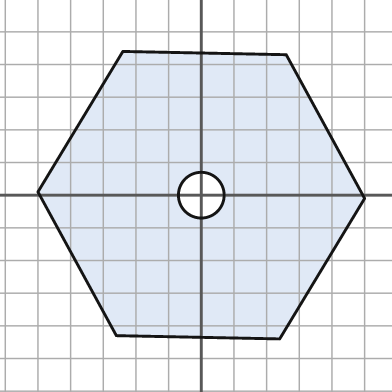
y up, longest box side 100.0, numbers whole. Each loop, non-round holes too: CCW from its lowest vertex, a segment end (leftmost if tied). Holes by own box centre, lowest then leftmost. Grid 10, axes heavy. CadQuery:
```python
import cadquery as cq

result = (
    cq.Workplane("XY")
    .moveTo(24.0, -44.0)
    .lineTo(50.0, -1.0)
    .lineTo(26.0, 43.0)
    .lineTo(-24.0, 44.0)
    .lineTo(-50.0, 1.0)
    .lineTo(-26.0, -43.0)
    .close()
    .moveTo(0.0, 0.0)
    .circle(7.0)
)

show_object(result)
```